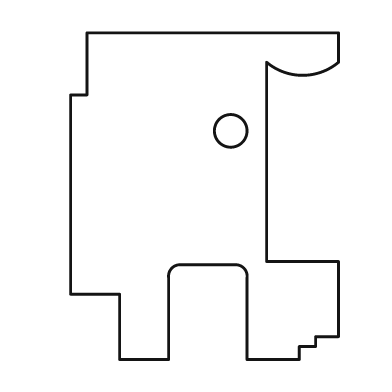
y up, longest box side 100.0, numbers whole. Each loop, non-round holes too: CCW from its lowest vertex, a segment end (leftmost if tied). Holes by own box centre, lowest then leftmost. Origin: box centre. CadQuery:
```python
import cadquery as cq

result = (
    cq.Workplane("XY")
    .moveTo(-26.0, -50.0)
    .lineTo(-11.0, -50.0)
    .lineTo(-11.0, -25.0)
    .threePointArc((-10.0, -22.0), (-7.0, -21.0))
    .lineTo(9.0, -21.0)
    .threePointArc((12.0, -22.0), (13.0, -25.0))
    .lineTo(13.0, -50.0)
    .lineTo(29.0, -50.0)
    .lineTo(29.0, -46.0)
    .lineTo(34.0, -46.0)
    .lineTo(34.0, -43.0)
    .lineTo(41.0, -43.0)
    .lineTo(41.0, -20.0)
    .lineTo(19.0, -20.0)
    .lineTo(19.0, 41.0)
    .threePointArc((30.0, 37.0), (41.0, 41.0))
    .lineTo(41.0, 50.0)
    .lineTo(-36.0, 50.0)
    .lineTo(-36.0, 31.0)
    .lineTo(-41.0, 31.0)
    .lineTo(-41.0, -30.0)
    .lineTo(-26.0, -30.0)
    .close()
    .moveTo(8.0, 20.0)
    .circle(5.0)
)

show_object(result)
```